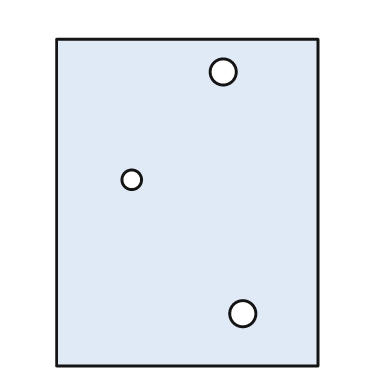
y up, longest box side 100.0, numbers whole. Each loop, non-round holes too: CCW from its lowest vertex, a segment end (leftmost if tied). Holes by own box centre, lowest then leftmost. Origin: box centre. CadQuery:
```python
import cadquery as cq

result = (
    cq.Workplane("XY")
    .moveTo(-40.0, -50.0)
    .lineTo(40.0, -50.0)
    .lineTo(40.0, 50.0)
    .lineTo(-40.0, 50.0)
    .close()
    .moveTo(17.0, -34.0)
    .circle(4.0)
    .moveTo(-17.0, 7.0)
    .circle(3.0)
    .moveTo(11.0, 40.0)
    .circle(4.0)
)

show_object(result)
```